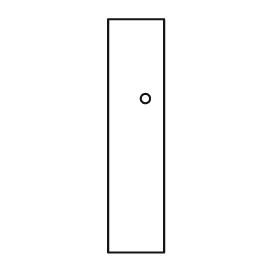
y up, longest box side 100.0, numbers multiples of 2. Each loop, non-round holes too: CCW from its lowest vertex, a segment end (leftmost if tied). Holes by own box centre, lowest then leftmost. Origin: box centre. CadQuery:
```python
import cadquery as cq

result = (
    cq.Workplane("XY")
    .moveTo(-12.0, -50.0)
    .lineTo(12.0, -50.0)
    .lineTo(12.0, 50.0)
    .lineTo(-12.0, 50.0)
    .close()
    .moveTo(4.0, 16.0)
    .circle(2.0)
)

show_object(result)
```